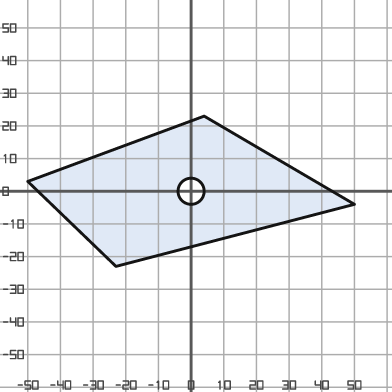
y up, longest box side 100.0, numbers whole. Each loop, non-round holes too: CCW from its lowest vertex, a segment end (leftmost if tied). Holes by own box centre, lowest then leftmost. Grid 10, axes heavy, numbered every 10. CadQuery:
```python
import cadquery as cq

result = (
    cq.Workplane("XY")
    .moveTo(-23.0, -23.0)
    .lineTo(50.0, -4.0)
    .lineTo(4.0, 23.0)
    .lineTo(-50.0, 3.0)
    .close()
    .moveTo(0.0, 0.0)
    .circle(4.0)
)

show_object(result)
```